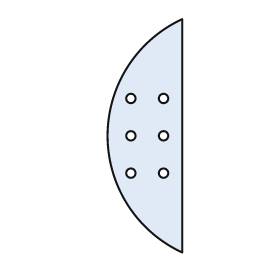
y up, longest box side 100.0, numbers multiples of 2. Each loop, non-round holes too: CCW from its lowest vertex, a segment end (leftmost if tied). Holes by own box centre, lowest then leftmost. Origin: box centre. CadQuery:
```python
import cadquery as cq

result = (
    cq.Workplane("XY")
    .moveTo(16.0, -50.0)
    .lineTo(16.0, 50.0)
    .threePointArc((-16.0, 0.0), (16.0, -50.0))
    .close()
    .moveTo(-6.0, -16.0)
    .circle(2.0)
    .moveTo(8.0, -16.0)
    .circle(2.0)
    .moveTo(-6.0, 0.0)
    .circle(2.0)
    .moveTo(8.0, 0.0)
    .circle(2.0)
    .moveTo(-6.0, 16.0)
    .circle(2.0)
    .moveTo(8.0, 16.0)
    .circle(2.0)
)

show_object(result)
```